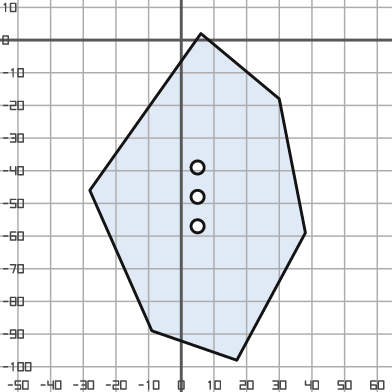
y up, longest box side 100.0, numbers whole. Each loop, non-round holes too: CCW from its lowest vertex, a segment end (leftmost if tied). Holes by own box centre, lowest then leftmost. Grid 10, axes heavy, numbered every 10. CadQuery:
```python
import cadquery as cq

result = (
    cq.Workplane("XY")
    .moveTo(17.0, -98.0)
    .lineTo(38.0, -59.0)
    .lineTo(30.0, -18.0)
    .lineTo(6.0, 2.0)
    .lineTo(-28.0, -46.0)
    .lineTo(-9.0, -89.0)
    .close()
    .moveTo(5.0, -57.0)
    .circle(2.0)
    .moveTo(5.0, -48.0)
    .circle(2.0)
    .moveTo(5.0, -39.0)
    .circle(2.0)
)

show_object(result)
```